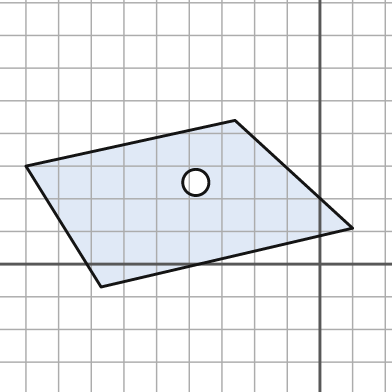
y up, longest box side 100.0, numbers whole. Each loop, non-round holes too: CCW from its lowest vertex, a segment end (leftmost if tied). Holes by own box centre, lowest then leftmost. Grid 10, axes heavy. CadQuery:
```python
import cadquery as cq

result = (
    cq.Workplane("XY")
    .moveTo(-67.0, -7.0)
    .lineTo(10.0, 11.0)
    .lineTo(-26.0, 44.0)
    .lineTo(-90.0, 30.0)
    .close()
    .moveTo(-38.0, 25.0)
    .circle(4.0)
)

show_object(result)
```